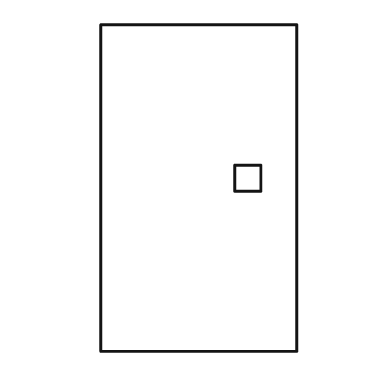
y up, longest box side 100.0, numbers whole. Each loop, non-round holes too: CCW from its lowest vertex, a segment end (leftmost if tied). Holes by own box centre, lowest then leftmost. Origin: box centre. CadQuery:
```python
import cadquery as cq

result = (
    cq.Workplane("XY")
    .moveTo(-30.0, -50.0)
    .lineTo(30.0, -50.0)
    .lineTo(30.0, 50.0)
    .lineTo(-30.0, 50.0)
    .close()
    .moveTo(11.0, -1.0)
    .lineTo(19.0, -1.0)
    .lineTo(19.0, 7.0)
    .lineTo(11.0, 7.0)
    .close()
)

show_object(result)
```